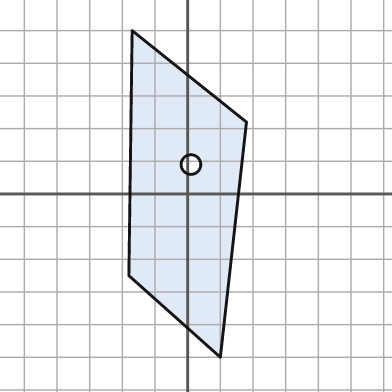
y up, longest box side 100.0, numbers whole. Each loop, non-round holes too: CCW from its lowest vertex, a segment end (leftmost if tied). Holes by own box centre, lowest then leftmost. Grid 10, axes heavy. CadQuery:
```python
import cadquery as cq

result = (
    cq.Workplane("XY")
    .moveTo(10.0, -50.0)
    .lineTo(18.0, 22.0)
    .lineTo(-17.0, 50.0)
    .lineTo(-18.0, -25.0)
    .close()
    .moveTo(1.0, 9.0)
    .circle(3.0)
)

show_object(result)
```